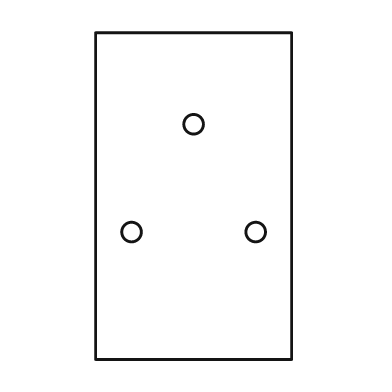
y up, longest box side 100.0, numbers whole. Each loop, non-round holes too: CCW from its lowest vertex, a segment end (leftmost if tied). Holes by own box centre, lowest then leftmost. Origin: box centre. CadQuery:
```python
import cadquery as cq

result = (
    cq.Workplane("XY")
    .moveTo(-30.0, -50.0)
    .lineTo(30.0, -50.0)
    .lineTo(30.0, 50.0)
    .lineTo(-30.0, 50.0)
    .close()
    .moveTo(-19.0, -11.0)
    .circle(3.0)
    .moveTo(19.0, -11.0)
    .circle(3.0)
    .moveTo(0.0, 22.0)
    .circle(3.0)
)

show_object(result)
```